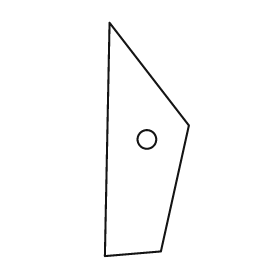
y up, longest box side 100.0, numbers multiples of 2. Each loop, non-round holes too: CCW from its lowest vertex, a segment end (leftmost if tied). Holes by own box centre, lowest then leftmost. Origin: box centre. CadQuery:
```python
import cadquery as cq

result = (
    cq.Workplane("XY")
    .moveTo(-18.0, -50.0)
    .lineTo(6.0, -48.0)
    .lineTo(18.0, 6.0)
    .lineTo(-16.0, 50.0)
    .close()
    .moveTo(0.0, 0.0)
    .circle(4.0)
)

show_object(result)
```